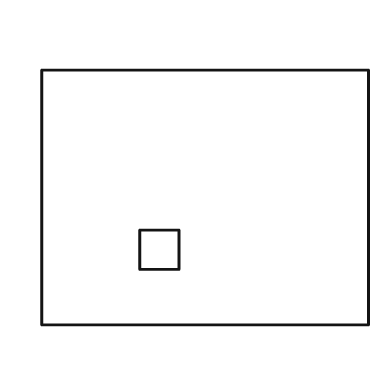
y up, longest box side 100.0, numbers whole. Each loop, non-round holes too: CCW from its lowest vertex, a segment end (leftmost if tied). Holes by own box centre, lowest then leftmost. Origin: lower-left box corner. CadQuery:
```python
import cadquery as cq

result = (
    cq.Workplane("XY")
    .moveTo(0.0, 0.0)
    .lineTo(100.0, 0.0)
    .lineTo(100.0, 78.0)
    .lineTo(0.0, 78.0)
    .close()
    .moveTo(30.0, 17.0)
    .lineTo(42.0, 17.0)
    .lineTo(42.0, 29.0)
    .lineTo(30.0, 29.0)
    .close()
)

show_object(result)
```